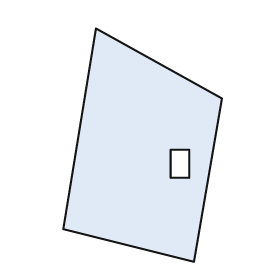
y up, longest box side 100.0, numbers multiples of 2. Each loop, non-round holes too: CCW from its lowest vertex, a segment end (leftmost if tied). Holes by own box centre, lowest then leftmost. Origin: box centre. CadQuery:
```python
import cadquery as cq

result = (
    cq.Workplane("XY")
    .moveTo(22.0, -50.0)
    .lineTo(34.0, 20.0)
    .lineTo(-20.0, 50.0)
    .lineTo(-34.0, -36.0)
    .close()
    .moveTo(12.0, -14.0)
    .lineTo(20.0, -14.0)
    .lineTo(20.0, -2.0)
    .lineTo(12.0, -2.0)
    .close()
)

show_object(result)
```